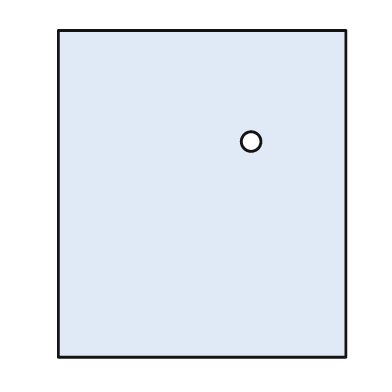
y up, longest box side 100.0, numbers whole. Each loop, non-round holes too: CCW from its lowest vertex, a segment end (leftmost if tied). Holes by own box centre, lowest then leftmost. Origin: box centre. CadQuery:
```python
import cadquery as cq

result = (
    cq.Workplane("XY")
    .moveTo(-44.0, -50.0)
    .lineTo(44.0, -50.0)
    .lineTo(44.0, 50.0)
    .lineTo(-44.0, 50.0)
    .close()
    .moveTo(15.0, 16.0)
    .circle(3.0)
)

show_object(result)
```